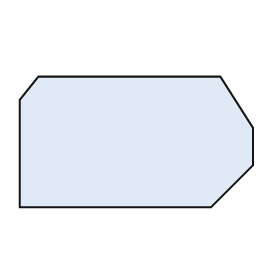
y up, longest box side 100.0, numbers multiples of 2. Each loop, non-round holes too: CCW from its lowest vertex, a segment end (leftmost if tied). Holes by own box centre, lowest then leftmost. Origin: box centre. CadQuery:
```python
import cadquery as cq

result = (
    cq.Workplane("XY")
    .moveTo(-50.0, -28.0)
    .lineTo(32.0, -28.0)
    .lineTo(50.0, -10.0)
    .lineTo(50.0, 6.0)
    .lineTo(36.0, 28.0)
    .lineTo(-42.0, 28.0)
    .lineTo(-50.0, 18.0)
    .close()
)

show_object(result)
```